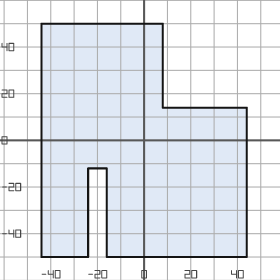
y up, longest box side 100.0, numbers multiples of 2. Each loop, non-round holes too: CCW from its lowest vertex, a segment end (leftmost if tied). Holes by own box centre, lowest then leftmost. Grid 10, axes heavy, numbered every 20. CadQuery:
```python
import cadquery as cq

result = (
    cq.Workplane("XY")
    .moveTo(-44.0, -50.0)
    .lineTo(-24.0, -50.0)
    .lineTo(-24.0, -12.0)
    .lineTo(-16.0, -12.0)
    .lineTo(-16.0, -50.0)
    .lineTo(44.0, -50.0)
    .lineTo(44.0, 14.0)
    .lineTo(8.0, 14.0)
    .lineTo(8.0, 50.0)
    .lineTo(-44.0, 50.0)
    .close()
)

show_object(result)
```